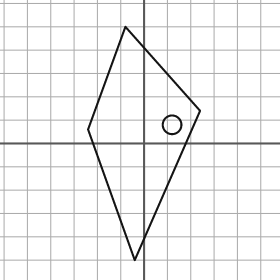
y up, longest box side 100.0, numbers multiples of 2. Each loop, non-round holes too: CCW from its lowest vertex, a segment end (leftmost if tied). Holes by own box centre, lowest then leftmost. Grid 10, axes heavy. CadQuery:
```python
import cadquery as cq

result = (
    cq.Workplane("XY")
    .moveTo(-4.0, -50.0)
    .lineTo(24.0, 14.0)
    .lineTo(-8.0, 50.0)
    .lineTo(-24.0, 6.0)
    .close()
    .moveTo(12.0, 8.0)
    .circle(4.0)
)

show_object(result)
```